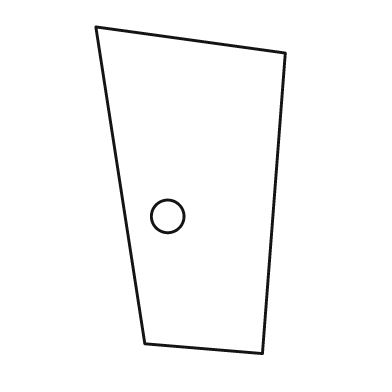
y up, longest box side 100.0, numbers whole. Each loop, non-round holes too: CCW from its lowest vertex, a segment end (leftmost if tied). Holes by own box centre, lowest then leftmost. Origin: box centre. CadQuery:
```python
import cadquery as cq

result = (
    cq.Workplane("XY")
    .moveTo(22.0, -50.0)
    .lineTo(29.0, 42.0)
    .lineTo(-29.0, 50.0)
    .lineTo(-14.0, -47.0)
    .close()
    .moveTo(-7.0, -8.0)
    .circle(5.0)
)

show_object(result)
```